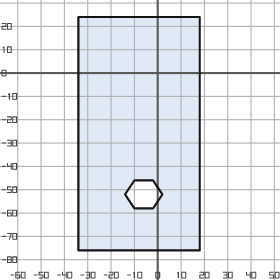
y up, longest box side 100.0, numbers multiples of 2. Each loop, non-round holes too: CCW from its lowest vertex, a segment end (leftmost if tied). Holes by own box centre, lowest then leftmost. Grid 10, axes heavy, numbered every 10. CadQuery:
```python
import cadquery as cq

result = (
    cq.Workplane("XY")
    .moveTo(-34.0, -76.0)
    .lineTo(18.0, -76.0)
    .lineTo(18.0, 24.0)
    .lineTo(-34.0, 24.0)
    .close()
    .moveTo(-10.0, -58.0)
    .lineTo(-2.0, -58.0)
    .lineTo(2.0, -52.0)
    .lineTo(-2.0, -46.0)
    .lineTo(-10.0, -46.0)
    .lineTo(-14.0, -52.0)
    .close()
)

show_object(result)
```